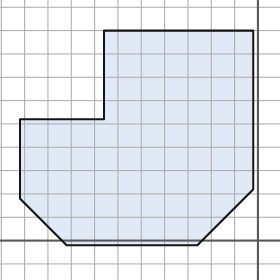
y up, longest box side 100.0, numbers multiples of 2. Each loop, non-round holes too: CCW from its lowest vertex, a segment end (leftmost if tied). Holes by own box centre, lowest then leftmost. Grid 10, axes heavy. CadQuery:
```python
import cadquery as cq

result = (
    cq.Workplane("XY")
    .moveTo(-82.0, -2.0)
    .lineTo(-26.0, -2.0)
    .lineTo(-2.0, 22.0)
    .lineTo(-2.0, 90.0)
    .lineTo(-66.0, 90.0)
    .lineTo(-66.0, 52.0)
    .lineTo(-102.0, 52.0)
    .lineTo(-102.0, 18.0)
    .close()
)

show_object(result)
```